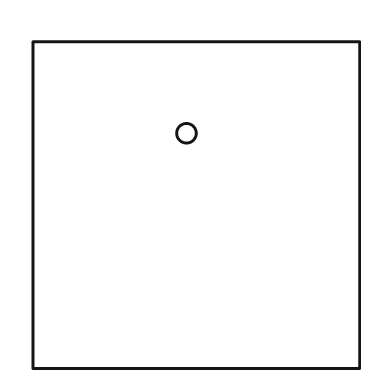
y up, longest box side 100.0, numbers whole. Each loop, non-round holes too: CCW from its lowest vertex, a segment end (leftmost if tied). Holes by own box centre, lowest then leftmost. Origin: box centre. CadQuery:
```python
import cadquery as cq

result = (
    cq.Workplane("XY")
    .moveTo(-50.0, -50.0)
    .lineTo(50.0, -50.0)
    .lineTo(50.0, 50.0)
    .lineTo(-50.0, 50.0)
    .close()
    .moveTo(-3.0, 22.0)
    .circle(3.0)
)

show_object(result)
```